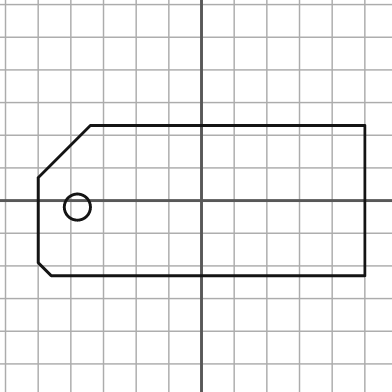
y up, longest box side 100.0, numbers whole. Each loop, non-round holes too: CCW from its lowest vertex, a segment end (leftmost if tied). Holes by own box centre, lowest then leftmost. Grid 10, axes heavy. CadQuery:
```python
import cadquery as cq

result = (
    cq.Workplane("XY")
    .moveTo(-46.0, -23.0)
    .lineTo(50.0, -23.0)
    .lineTo(50.0, 23.0)
    .lineTo(-34.0, 23.0)
    .lineTo(-50.0, 7.0)
    .lineTo(-50.0, -19.0)
    .close()
    .moveTo(-38.0, -2.0)
    .circle(4.0)
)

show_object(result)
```